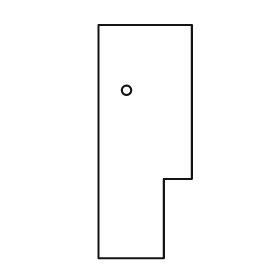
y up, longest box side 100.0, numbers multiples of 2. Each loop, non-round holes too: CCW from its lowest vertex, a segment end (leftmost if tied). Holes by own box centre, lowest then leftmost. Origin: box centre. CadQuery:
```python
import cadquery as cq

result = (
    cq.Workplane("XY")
    .moveTo(-20.0, -50.0)
    .lineTo(8.0, -50.0)
    .lineTo(8.0, -16.0)
    .lineTo(20.0, -16.0)
    .lineTo(20.0, 50.0)
    .lineTo(-20.0, 50.0)
    .close()
    .moveTo(-8.0, 22.0)
    .circle(2.0)
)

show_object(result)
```